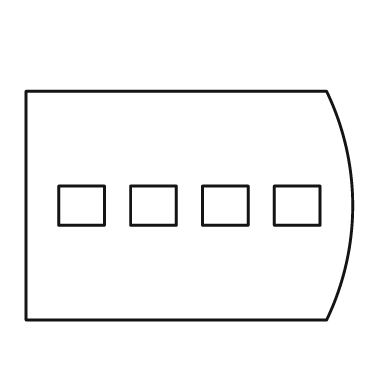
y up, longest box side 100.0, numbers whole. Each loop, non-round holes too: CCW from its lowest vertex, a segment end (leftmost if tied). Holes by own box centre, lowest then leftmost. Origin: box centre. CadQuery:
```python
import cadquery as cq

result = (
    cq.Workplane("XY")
    .moveTo(-50.0, -35.0)
    .lineTo(42.0, -35.0)
    .threePointArc((50.0, 0.0), (42.0, 35.0))
    .lineTo(-50.0, 35.0)
    .close()
    .moveTo(-40.0, -6.0)
    .lineTo(-26.0, -6.0)
    .lineTo(-26.0, 6.0)
    .lineTo(-40.0, 6.0)
    .close()
    .moveTo(-18.0, -6.0)
    .lineTo(-4.0, -6.0)
    .lineTo(-4.0, 6.0)
    .lineTo(-18.0, 6.0)
    .close()
    .moveTo(4.0, -6.0)
    .lineTo(18.0, -6.0)
    .lineTo(18.0, 6.0)
    .lineTo(4.0, 6.0)
    .close()
    .moveTo(26.0, -6.0)
    .lineTo(40.0, -6.0)
    .lineTo(40.0, 6.0)
    .lineTo(26.0, 6.0)
    .close()
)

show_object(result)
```